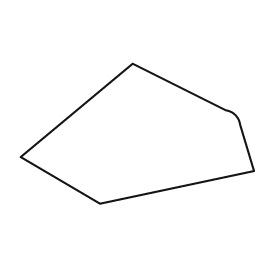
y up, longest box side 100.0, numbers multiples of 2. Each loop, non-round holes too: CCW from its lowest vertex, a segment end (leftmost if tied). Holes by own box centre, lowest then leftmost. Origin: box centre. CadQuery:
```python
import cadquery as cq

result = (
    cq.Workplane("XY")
    .moveTo(-16.0, -30.0)
    .lineTo(50.0, -16.0)
    .lineTo(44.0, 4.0)
    .threePointArc((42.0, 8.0), (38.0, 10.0))
    .lineTo(-2.0, 30.0)
    .lineTo(-50.0, -10.0)
    .close()
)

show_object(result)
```